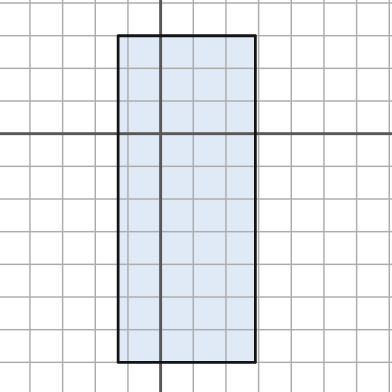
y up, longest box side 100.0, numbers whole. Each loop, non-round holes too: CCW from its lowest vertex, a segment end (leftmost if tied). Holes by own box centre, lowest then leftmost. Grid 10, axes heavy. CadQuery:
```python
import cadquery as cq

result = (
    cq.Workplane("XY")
    .moveTo(-13.0, -70.0)
    .lineTo(29.0, -70.0)
    .lineTo(29.0, 30.0)
    .lineTo(-13.0, 30.0)
    .close()
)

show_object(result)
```